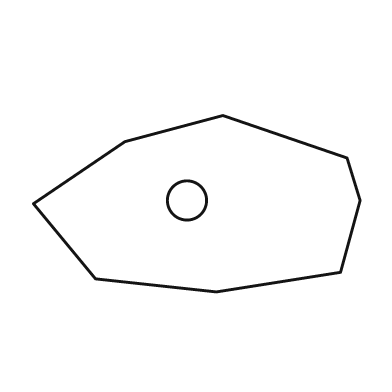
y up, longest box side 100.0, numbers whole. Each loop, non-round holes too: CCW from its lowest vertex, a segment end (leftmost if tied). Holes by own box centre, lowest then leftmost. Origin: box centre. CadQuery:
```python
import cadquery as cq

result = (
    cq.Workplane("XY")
    .moveTo(6.0, -27.0)
    .lineTo(44.0, -21.0)
    .lineTo(50.0, 1.0)
    .lineTo(46.0, 14.0)
    .lineTo(8.0, 27.0)
    .lineTo(-22.0, 19.0)
    .lineTo(-50.0, 0.0)
    .lineTo(-31.0, -23.0)
    .close()
    .moveTo(-3.0, 1.0)
    .circle(6.0)
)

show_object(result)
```